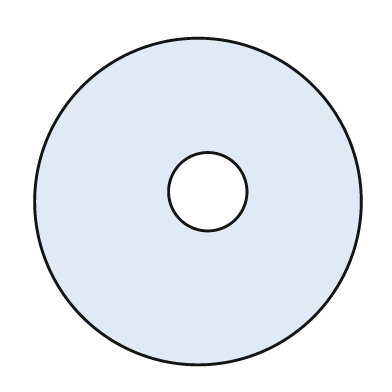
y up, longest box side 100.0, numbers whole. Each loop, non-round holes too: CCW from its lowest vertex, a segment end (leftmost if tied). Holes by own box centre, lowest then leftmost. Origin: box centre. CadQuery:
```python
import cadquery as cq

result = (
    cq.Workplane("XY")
    .moveTo(0.0, 0.0)
    .circle(50.0)
    .moveTo(3.0, 3.0)
    .circle(12.0)
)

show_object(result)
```